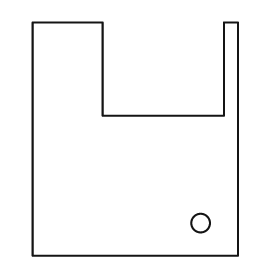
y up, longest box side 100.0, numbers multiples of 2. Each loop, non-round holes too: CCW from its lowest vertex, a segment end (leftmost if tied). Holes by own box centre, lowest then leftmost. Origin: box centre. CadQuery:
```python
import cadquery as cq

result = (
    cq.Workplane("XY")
    .moveTo(-44.0, -50.0)
    .lineTo(44.0, -50.0)
    .lineTo(44.0, 50.0)
    .lineTo(38.0, 50.0)
    .lineTo(38.0, 10.0)
    .lineTo(-14.0, 10.0)
    .lineTo(-14.0, 50.0)
    .lineTo(-44.0, 50.0)
    .close()
    .moveTo(28.0, -36.0)
    .circle(4.0)
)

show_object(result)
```